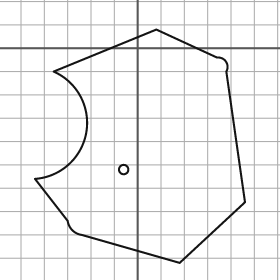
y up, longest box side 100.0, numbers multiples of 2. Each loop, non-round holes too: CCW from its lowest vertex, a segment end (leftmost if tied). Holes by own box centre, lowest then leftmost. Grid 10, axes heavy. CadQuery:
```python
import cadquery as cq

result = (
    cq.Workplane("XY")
    .moveTo(18.0, -92.0)
    .lineTo(46.0, -66.0)
    .lineTo(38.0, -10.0)
    .threePointArc((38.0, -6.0), (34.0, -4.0))
    .lineTo(8.0, 8.0)
    .lineTo(-36.0, -10.0)
    .threePointArc((-22.0, -36.0), (-44.0, -56.0))
    .lineTo(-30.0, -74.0)
    .threePointArc((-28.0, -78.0), (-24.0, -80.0))
    .close()
    .moveTo(-6.0, -52.0)
    .circle(2.0)
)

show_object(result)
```